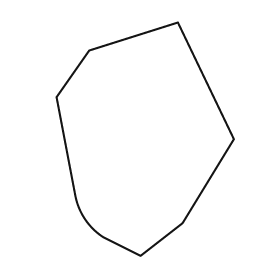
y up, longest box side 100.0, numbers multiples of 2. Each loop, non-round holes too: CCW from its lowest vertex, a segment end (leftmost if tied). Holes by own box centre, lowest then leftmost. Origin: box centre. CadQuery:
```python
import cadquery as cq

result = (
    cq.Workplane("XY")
    .moveTo(-2.0, -50.0)
    .lineTo(16.0, -36.0)
    .lineTo(38.0, 0.0)
    .lineTo(14.0, 50.0)
    .lineTo(-24.0, 38.0)
    .lineTo(-38.0, 18.0)
    .lineTo(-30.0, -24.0)
    .threePointArc((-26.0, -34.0), (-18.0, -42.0))
    .close()
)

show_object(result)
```